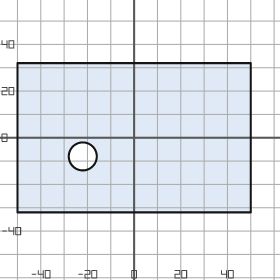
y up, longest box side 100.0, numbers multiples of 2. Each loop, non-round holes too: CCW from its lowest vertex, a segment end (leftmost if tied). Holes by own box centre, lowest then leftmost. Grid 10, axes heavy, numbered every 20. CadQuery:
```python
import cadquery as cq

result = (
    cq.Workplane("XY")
    .moveTo(-50.0, -32.0)
    .lineTo(50.0, -32.0)
    .lineTo(50.0, 32.0)
    .lineTo(-50.0, 32.0)
    .close()
    .moveTo(-22.0, -8.0)
    .circle(6.0)
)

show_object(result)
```